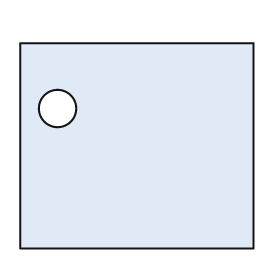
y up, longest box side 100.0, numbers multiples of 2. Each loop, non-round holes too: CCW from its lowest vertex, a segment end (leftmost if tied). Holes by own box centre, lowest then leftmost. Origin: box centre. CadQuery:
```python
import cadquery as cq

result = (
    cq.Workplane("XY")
    .moveTo(-50.0, -44.0)
    .lineTo(50.0, -44.0)
    .lineTo(50.0, 44.0)
    .lineTo(-50.0, 44.0)
    .close()
    .moveTo(-34.0, 16.0)
    .circle(8.0)
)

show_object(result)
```